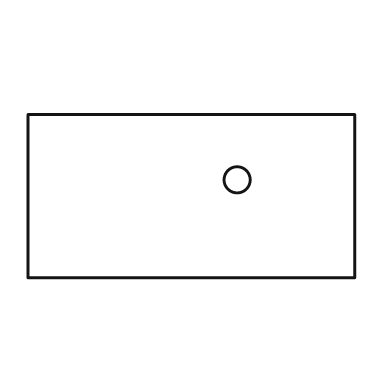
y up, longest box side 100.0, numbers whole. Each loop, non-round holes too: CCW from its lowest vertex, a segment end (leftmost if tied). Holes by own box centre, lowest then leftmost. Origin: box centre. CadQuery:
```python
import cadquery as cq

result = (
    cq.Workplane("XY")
    .moveTo(-50.0, -25.0)
    .lineTo(50.0, -25.0)
    .lineTo(50.0, 25.0)
    .lineTo(-50.0, 25.0)
    .close()
    .moveTo(14.0, 5.0)
    .circle(4.0)
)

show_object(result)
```